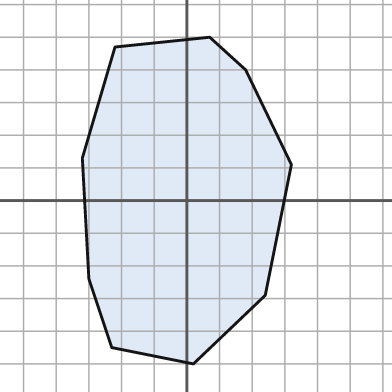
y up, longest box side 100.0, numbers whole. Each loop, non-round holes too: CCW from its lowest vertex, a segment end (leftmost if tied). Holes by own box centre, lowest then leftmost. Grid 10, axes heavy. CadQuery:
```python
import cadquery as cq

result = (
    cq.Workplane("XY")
    .moveTo(2.0, -50.0)
    .lineTo(24.0, -29.0)
    .lineTo(32.0, 11.0)
    .lineTo(18.0, 40.0)
    .lineTo(7.0, 50.0)
    .lineTo(-22.0, 47.0)
    .lineTo(-32.0, 13.0)
    .lineTo(-30.0, -24.0)
    .lineTo(-23.0, -45.0)
    .close()
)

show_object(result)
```